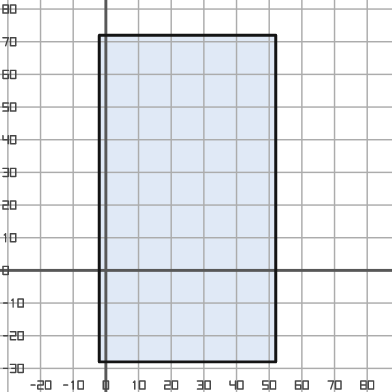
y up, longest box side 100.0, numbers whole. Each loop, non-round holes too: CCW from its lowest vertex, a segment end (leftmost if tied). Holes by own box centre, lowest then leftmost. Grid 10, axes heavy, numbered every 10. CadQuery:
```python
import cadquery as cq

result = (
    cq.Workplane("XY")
    .moveTo(-2.0, -28.0)
    .lineTo(52.0, -28.0)
    .lineTo(52.0, 72.0)
    .lineTo(-2.0, 72.0)
    .close()
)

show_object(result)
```